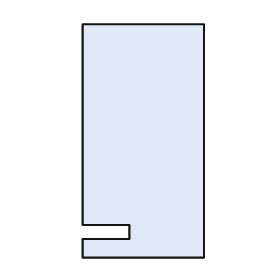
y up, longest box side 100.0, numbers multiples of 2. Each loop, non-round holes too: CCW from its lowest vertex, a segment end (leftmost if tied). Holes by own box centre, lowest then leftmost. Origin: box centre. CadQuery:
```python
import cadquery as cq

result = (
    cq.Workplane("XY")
    .moveTo(-26.0, -50.0)
    .lineTo(26.0, -50.0)
    .lineTo(26.0, 50.0)
    .lineTo(-26.0, 50.0)
    .lineTo(-26.0, -36.0)
    .lineTo(-6.0, -36.0)
    .lineTo(-6.0, -42.0)
    .lineTo(-26.0, -42.0)
    .close()
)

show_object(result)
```